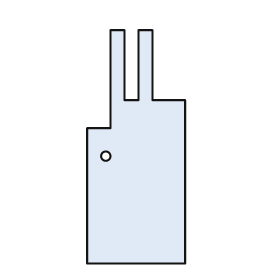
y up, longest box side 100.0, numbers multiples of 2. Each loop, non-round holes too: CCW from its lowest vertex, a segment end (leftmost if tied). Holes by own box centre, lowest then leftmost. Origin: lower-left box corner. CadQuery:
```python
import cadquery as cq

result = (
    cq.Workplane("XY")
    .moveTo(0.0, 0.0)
    .lineTo(42.0, 0.0)
    .lineTo(42.0, 70.0)
    .lineTo(28.0, 70.0)
    .lineTo(28.0, 100.0)
    .lineTo(22.0, 100.0)
    .lineTo(22.0, 70.0)
    .lineTo(16.0, 70.0)
    .lineTo(16.0, 100.0)
    .lineTo(10.0, 100.0)
    .lineTo(10.0, 58.0)
    .lineTo(0.0, 58.0)
    .close()
    .moveTo(8.0, 46.0)
    .circle(2.0)
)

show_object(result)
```